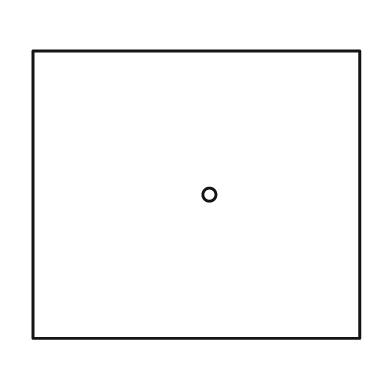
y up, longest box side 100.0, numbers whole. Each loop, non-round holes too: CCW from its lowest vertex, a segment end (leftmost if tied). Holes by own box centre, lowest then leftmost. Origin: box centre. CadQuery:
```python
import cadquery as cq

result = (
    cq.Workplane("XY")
    .moveTo(-50.0, -44.0)
    .lineTo(50.0, -44.0)
    .lineTo(50.0, 44.0)
    .lineTo(-50.0, 44.0)
    .close()
    .moveTo(4.0, 0.0)
    .circle(2.0)
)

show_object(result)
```